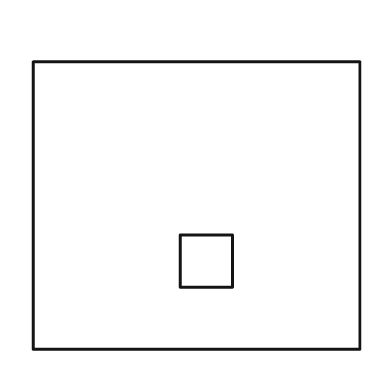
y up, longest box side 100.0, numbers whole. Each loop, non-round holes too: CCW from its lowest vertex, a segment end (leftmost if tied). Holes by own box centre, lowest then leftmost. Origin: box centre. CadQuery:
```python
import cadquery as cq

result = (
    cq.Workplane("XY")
    .moveTo(-50.0, -44.0)
    .lineTo(50.0, -44.0)
    .lineTo(50.0, 44.0)
    .lineTo(-50.0, 44.0)
    .close()
    .moveTo(-5.0, -25.0)
    .lineTo(11.0, -25.0)
    .lineTo(11.0, -9.0)
    .lineTo(-5.0, -9.0)
    .close()
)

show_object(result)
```